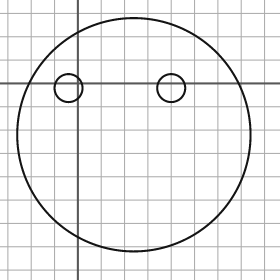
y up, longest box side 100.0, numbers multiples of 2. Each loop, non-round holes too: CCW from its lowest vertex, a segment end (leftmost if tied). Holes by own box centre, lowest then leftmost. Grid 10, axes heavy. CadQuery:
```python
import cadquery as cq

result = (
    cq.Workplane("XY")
    .moveTo(24.0, -22.0)
    .circle(50.0)
    .moveTo(-4.0, -2.0)
    .circle(6.0)
    .moveTo(40.0, -2.0)
    .circle(6.0)
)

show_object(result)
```